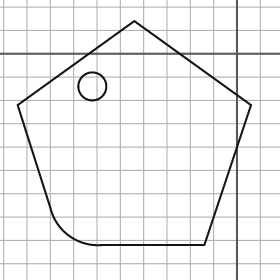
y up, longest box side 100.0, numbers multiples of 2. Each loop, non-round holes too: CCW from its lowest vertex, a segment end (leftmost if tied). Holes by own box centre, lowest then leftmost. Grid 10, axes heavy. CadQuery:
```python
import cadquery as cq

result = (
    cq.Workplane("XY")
    .moveTo(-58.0, -82.0)
    .lineTo(-14.0, -82.0)
    .lineTo(6.0, -22.0)
    .lineTo(-44.0, 14.0)
    .lineTo(-94.0, -22.0)
    .lineTo(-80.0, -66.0)
    .threePointArc((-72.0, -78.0), (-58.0, -82.0))
    .close()
    .moveTo(-62.0, -14.0)
    .circle(6.0)
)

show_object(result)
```